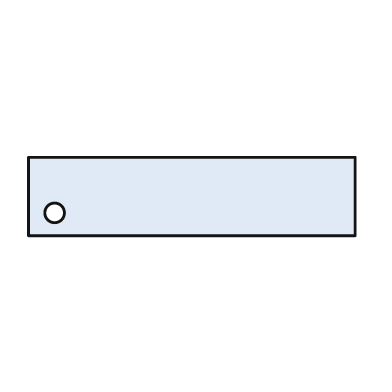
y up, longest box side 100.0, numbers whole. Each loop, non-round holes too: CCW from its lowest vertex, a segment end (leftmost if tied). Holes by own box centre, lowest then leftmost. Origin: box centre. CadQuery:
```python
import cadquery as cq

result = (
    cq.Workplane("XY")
    .moveTo(-50.0, -12.0)
    .lineTo(50.0, -12.0)
    .lineTo(50.0, 12.0)
    .lineTo(-50.0, 12.0)
    .close()
    .moveTo(-42.0, -5.0)
    .circle(3.0)
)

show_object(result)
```